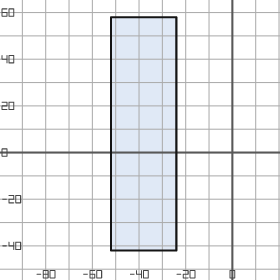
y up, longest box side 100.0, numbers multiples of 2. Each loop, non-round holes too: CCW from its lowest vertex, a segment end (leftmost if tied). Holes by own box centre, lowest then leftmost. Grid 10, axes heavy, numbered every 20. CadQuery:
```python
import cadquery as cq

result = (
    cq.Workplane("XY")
    .moveTo(-52.0, -42.0)
    .lineTo(-24.0, -42.0)
    .lineTo(-24.0, 58.0)
    .lineTo(-52.0, 58.0)
    .close()
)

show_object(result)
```